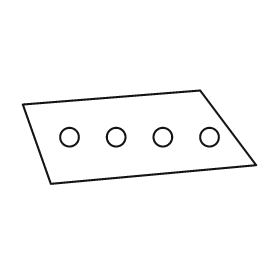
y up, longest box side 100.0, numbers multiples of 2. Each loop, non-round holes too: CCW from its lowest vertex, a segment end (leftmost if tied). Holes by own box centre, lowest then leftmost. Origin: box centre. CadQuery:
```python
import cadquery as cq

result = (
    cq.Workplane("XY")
    .moveTo(-38.0, -20.0)
    .lineTo(50.0, -12.0)
    .lineTo(26.0, 20.0)
    .lineTo(-50.0, 14.0)
    .close()
    .moveTo(-30.0, 0.0)
    .circle(4.0)
    .moveTo(-10.0, 0.0)
    .circle(4.0)
    .moveTo(10.0, 0.0)
    .circle(4.0)
    .moveTo(30.0, 0.0)
    .circle(4.0)
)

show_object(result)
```